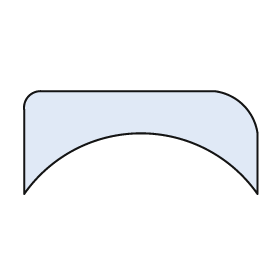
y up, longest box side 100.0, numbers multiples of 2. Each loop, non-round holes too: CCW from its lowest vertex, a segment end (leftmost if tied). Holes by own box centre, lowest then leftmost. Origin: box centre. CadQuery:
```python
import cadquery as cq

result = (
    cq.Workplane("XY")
    .moveTo(-50.0, -22.0)
    .threePointArc((0.0, 4.0), (50.0, -22.0))
    .lineTo(50.0, 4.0)
    .threePointArc((44.0, 16.0), (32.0, 22.0))
    .lineTo(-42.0, 22.0)
    .threePointArc((-48.0, 20.0), (-50.0, 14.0))
    .close()
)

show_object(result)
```